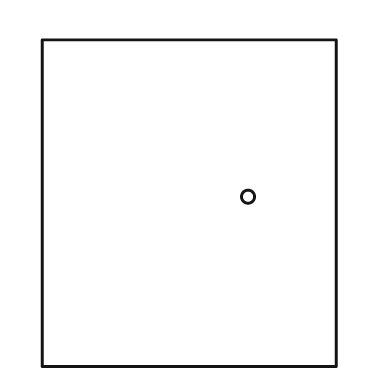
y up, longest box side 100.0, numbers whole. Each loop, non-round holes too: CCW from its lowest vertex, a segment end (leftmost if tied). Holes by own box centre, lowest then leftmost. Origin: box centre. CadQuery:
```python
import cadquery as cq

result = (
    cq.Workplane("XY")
    .moveTo(-45.0, -50.0)
    .lineTo(45.0, -50.0)
    .lineTo(45.0, 50.0)
    .lineTo(-45.0, 50.0)
    .close()
    .moveTo(18.0, 2.0)
    .circle(2.0)
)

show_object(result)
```